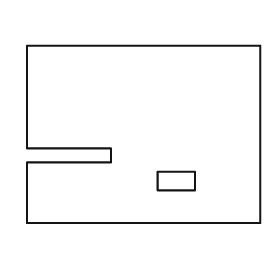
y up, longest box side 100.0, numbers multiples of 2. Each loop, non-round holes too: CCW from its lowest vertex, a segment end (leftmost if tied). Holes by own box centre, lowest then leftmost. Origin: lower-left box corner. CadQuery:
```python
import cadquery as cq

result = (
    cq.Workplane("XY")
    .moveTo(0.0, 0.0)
    .lineTo(100.0, 0.0)
    .lineTo(100.0, 76.0)
    .lineTo(0.0, 76.0)
    .lineTo(0.0, 32.0)
    .lineTo(36.0, 32.0)
    .lineTo(36.0, 26.0)
    .lineTo(0.0, 26.0)
    .close()
    .moveTo(56.0, 14.0)
    .lineTo(72.0, 14.0)
    .lineTo(72.0, 22.0)
    .lineTo(56.0, 22.0)
    .close()
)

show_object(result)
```